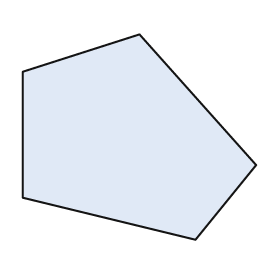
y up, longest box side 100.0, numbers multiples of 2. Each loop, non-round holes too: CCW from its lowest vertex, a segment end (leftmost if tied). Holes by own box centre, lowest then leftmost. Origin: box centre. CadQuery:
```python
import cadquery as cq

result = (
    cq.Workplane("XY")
    .moveTo(24.0, -44.0)
    .lineTo(50.0, -12.0)
    .lineTo(0.0, 44.0)
    .lineTo(-50.0, 28.0)
    .lineTo(-50.0, -26.0)
    .close()
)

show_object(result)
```